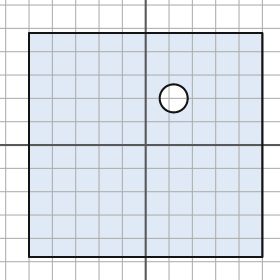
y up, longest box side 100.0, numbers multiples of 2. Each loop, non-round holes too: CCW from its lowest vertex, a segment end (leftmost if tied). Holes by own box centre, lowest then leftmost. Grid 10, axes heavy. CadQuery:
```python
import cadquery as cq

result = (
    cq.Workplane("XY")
    .moveTo(-50.0, -48.0)
    .lineTo(50.0, -48.0)
    .lineTo(50.0, 48.0)
    .lineTo(-50.0, 48.0)
    .close()
    .moveTo(12.0, 20.0)
    .circle(6.0)
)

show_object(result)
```